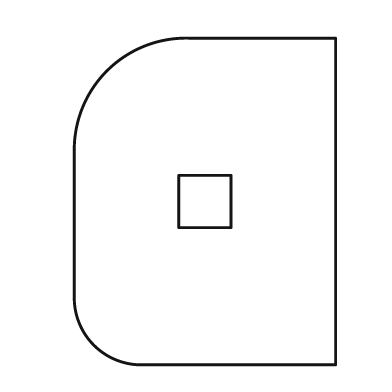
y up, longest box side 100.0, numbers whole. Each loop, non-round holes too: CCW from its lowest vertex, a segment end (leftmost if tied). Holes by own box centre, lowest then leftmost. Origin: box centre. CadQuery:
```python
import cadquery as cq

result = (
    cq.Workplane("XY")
    .moveTo(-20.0, -50.0)
    .lineTo(40.0, -50.0)
    .lineTo(40.0, 50.0)
    .lineTo(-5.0, 50.0)
    .threePointArc((-30.0, 40.0), (-40.0, 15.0))
    .lineTo(-40.0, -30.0)
    .threePointArc((-34.0, -44.0), (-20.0, -50.0))
    .close()
    .moveTo(-8.0, -8.0)
    .lineTo(8.0, -8.0)
    .lineTo(8.0, 8.0)
    .lineTo(-8.0, 8.0)
    .close()
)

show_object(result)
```